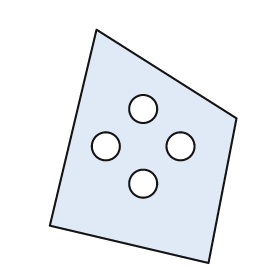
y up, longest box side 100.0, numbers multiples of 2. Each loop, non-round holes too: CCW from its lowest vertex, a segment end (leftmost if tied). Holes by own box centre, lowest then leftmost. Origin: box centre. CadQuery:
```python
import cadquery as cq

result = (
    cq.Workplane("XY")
    .moveTo(28.0, -50.0)
    .lineTo(40.0, 12.0)
    .lineTo(-20.0, 50.0)
    .lineTo(-40.0, -34.0)
    .close()
    .moveTo(0.0, -16.0)
    .circle(6.0)
    .moveTo(-16.0, 0.0)
    .circle(6.0)
    .moveTo(16.0, 0.0)
    .circle(6.0)
    .moveTo(0.0, 16.0)
    .circle(6.0)
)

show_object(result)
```